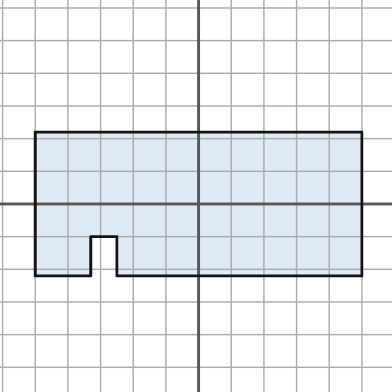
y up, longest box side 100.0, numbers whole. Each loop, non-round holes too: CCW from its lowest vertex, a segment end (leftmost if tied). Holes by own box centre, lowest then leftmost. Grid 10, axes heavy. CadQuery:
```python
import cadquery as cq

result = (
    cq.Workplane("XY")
    .moveTo(-50.0, -22.0)
    .lineTo(-33.0, -22.0)
    .lineTo(-33.0, -10.0)
    .lineTo(-25.0, -10.0)
    .lineTo(-25.0, -22.0)
    .lineTo(50.0, -22.0)
    .lineTo(50.0, 22.0)
    .lineTo(-50.0, 22.0)
    .close()
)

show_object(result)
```